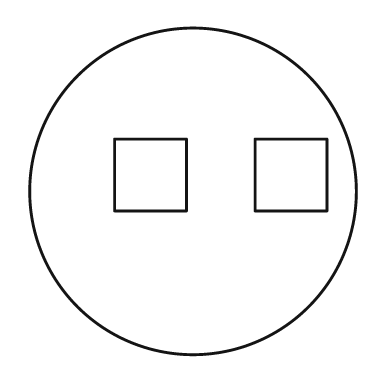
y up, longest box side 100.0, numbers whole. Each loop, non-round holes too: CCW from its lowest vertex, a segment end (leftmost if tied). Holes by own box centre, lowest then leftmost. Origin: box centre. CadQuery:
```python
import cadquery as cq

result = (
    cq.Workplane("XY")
    .moveTo(0.0, 0.0)
    .circle(50.0)
    .moveTo(-24.0, -6.0)
    .lineTo(-2.0, -6.0)
    .lineTo(-2.0, 16.0)
    .lineTo(-24.0, 16.0)
    .close()
    .moveTo(19.0, -6.0)
    .lineTo(41.0, -6.0)
    .lineTo(41.0, 16.0)
    .lineTo(19.0, 16.0)
    .close()
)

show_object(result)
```